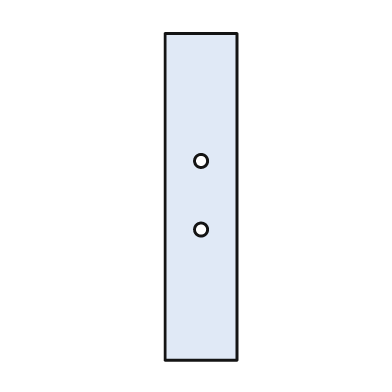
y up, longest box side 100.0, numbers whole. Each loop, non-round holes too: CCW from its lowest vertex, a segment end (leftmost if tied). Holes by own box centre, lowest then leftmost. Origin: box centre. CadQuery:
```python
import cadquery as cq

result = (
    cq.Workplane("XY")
    .moveTo(-11.0, -50.0)
    .lineTo(11.0, -50.0)
    .lineTo(11.0, 50.0)
    .lineTo(-11.0, 50.0)
    .close()
    .moveTo(0.0, -10.0)
    .circle(2.0)
    .moveTo(0.0, 11.0)
    .circle(2.0)
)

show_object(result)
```